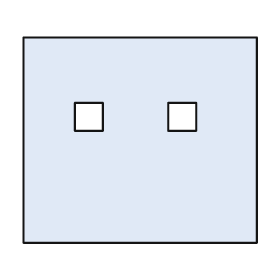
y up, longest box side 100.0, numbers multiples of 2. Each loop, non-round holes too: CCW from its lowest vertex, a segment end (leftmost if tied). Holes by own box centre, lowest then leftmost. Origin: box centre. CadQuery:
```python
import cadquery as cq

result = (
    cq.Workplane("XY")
    .moveTo(-50.0, -44.0)
    .lineTo(50.0, -44.0)
    .lineTo(50.0, 44.0)
    .lineTo(-50.0, 44.0)
    .close()
    .moveTo(-28.0, 4.0)
    .lineTo(-16.0, 4.0)
    .lineTo(-16.0, 16.0)
    .lineTo(-28.0, 16.0)
    .close()
    .moveTo(12.0, 4.0)
    .lineTo(24.0, 4.0)
    .lineTo(24.0, 16.0)
    .lineTo(12.0, 16.0)
    .close()
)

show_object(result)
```